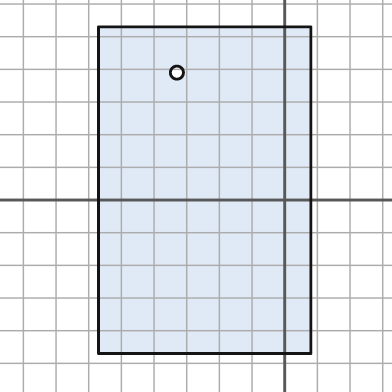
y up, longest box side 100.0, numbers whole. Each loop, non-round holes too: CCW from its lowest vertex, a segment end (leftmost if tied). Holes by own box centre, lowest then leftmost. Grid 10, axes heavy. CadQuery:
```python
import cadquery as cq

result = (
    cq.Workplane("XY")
    .moveTo(-57.0, -47.0)
    .lineTo(8.0, -47.0)
    .lineTo(8.0, 53.0)
    .lineTo(-57.0, 53.0)
    .close()
    .moveTo(-33.0, 39.0)
    .circle(2.0)
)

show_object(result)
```